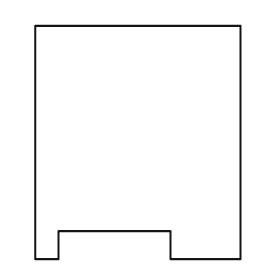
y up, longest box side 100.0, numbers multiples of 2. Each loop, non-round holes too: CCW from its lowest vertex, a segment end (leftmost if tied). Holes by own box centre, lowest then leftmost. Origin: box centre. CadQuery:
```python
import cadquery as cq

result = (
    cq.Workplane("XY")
    .moveTo(-44.0, -50.0)
    .lineTo(-34.0, -50.0)
    .lineTo(-34.0, -38.0)
    .lineTo(14.0, -38.0)
    .lineTo(14.0, -50.0)
    .lineTo(44.0, -50.0)
    .lineTo(44.0, 50.0)
    .lineTo(-44.0, 50.0)
    .close()
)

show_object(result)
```